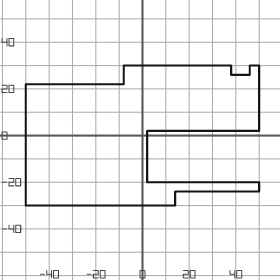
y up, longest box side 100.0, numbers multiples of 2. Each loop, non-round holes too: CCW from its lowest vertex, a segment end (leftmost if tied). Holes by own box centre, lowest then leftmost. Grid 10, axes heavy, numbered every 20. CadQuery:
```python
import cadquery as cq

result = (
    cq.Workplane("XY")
    .moveTo(-50.0, -30.0)
    .lineTo(14.0, -30.0)
    .lineTo(14.0, -24.0)
    .lineTo(50.0, -24.0)
    .lineTo(50.0, -20.0)
    .lineTo(2.0, -20.0)
    .lineTo(2.0, 2.0)
    .lineTo(50.0, 2.0)
    .lineTo(50.0, 30.0)
    .lineTo(46.0, 30.0)
    .lineTo(46.0, 26.0)
    .lineTo(38.0, 26.0)
    .lineTo(38.0, 30.0)
    .lineTo(-8.0, 30.0)
    .lineTo(-8.0, 22.0)
    .lineTo(-50.0, 22.0)
    .close()
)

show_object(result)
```